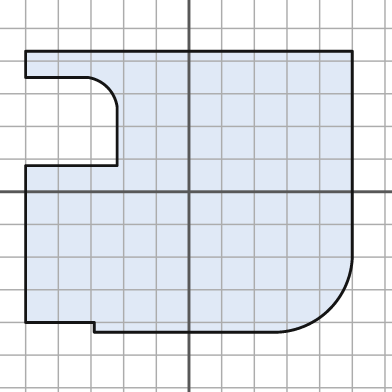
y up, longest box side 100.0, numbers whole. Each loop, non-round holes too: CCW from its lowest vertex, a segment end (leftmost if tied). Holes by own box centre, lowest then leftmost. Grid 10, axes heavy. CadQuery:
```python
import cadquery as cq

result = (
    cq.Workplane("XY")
    .moveTo(-29.0, -43.0)
    .lineTo(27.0, -43.0)
    .threePointArc((43.0, -36.0), (50.0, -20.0))
    .lineTo(50.0, 43.0)
    .lineTo(-50.0, 43.0)
    .lineTo(-50.0, 35.0)
    .lineTo(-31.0, 35.0)
    .threePointArc((-25.0, 32.0), (-22.0, 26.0))
    .lineTo(-22.0, 8.0)
    .lineTo(-50.0, 8.0)
    .lineTo(-50.0, -40.0)
    .lineTo(-29.0, -40.0)
    .close()
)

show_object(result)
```